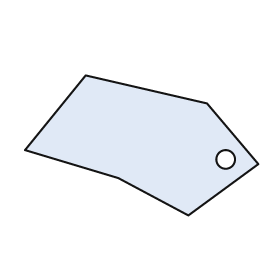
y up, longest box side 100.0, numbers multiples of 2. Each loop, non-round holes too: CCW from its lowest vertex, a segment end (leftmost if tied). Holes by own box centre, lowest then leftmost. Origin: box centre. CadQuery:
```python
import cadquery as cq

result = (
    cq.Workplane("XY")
    .moveTo(20.0, -30.0)
    .lineTo(50.0, -8.0)
    .lineTo(28.0, 18.0)
    .lineTo(-24.0, 30.0)
    .lineTo(-50.0, -2.0)
    .lineTo(-10.0, -14.0)
    .close()
    .moveTo(36.0, -6.0)
    .circle(4.0)
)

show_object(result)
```